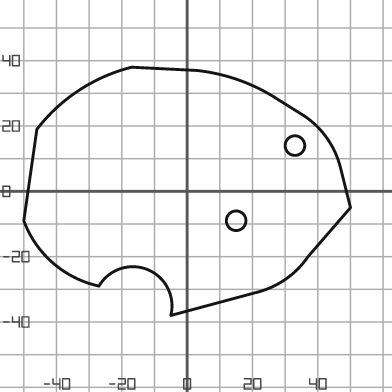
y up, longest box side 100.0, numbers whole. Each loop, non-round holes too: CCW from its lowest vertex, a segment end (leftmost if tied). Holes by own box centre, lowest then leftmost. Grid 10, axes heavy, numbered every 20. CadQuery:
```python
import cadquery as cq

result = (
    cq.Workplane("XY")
    .moveTo(-5.0, -38.0)
    .lineTo(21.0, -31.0)
    .threePointArc((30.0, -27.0), (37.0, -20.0))
    .lineTo(50.0, -5.0)
    .lineTo(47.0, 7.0)
    .threePointArc((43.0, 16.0), (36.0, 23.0))
    .lineTo(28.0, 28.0)
    .threePointArc((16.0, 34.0), (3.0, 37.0))
    .lineTo(-17.0, 38.0)
    .threePointArc((-33.0, 31.0), (-46.0, 19.0))
    .lineTo(-50.0, -9.0)
    .threePointArc((-41.0, -22.0), (-27.0, -29.0))
    .threePointArc((-12.0, -24.0), (-5.0, -38.0))
    .close()
    .moveTo(15.0, -9.0)
    .circle(3.0)
    .moveTo(33.0, 14.0)
    .circle(3.0)
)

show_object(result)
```